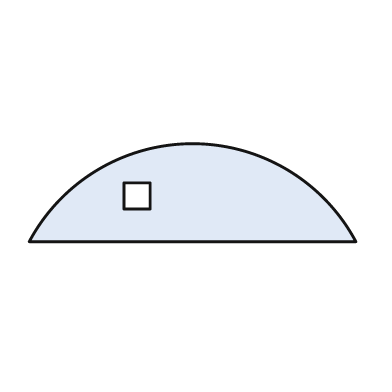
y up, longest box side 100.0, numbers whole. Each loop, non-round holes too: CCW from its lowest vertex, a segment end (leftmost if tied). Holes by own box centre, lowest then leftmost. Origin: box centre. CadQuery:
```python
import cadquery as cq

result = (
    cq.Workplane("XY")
    .moveTo(-50.0, -15.0)
    .lineTo(50.0, -15.0)
    .threePointArc((0.0, 15.0), (-50.0, -15.0))
    .close()
    .moveTo(-21.0, -5.0)
    .lineTo(-13.0, -5.0)
    .lineTo(-13.0, 3.0)
    .lineTo(-21.0, 3.0)
    .close()
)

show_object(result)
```